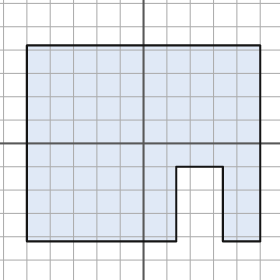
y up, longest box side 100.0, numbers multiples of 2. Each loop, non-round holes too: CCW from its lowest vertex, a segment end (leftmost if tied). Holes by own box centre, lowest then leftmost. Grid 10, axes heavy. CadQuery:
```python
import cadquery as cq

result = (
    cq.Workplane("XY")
    .moveTo(-50.0, -42.0)
    .lineTo(14.0, -42.0)
    .lineTo(14.0, -10.0)
    .lineTo(34.0, -10.0)
    .lineTo(34.0, -42.0)
    .lineTo(50.0, -42.0)
    .lineTo(50.0, 42.0)
    .lineTo(-50.0, 42.0)
    .close()
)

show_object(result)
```